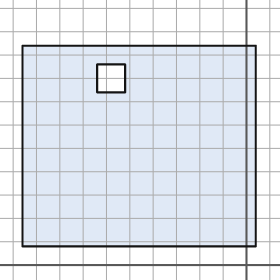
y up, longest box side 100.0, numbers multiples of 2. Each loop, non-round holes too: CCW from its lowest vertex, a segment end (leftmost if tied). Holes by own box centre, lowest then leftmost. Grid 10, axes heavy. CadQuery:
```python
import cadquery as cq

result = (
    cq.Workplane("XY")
    .moveTo(-96.0, 8.0)
    .lineTo(4.0, 8.0)
    .lineTo(4.0, 94.0)
    .lineTo(-96.0, 94.0)
    .close()
    .moveTo(-64.0, 74.0)
    .lineTo(-52.0, 74.0)
    .lineTo(-52.0, 86.0)
    .lineTo(-64.0, 86.0)
    .close()
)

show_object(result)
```